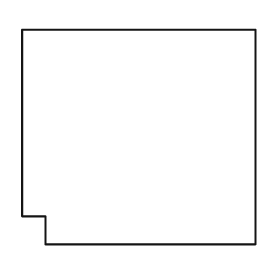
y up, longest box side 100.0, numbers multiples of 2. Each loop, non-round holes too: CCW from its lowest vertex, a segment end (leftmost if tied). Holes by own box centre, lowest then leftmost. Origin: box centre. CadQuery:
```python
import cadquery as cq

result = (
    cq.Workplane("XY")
    .moveTo(-40.0, -46.0)
    .lineTo(50.0, -46.0)
    .lineTo(50.0, 46.0)
    .lineTo(-50.0, 46.0)
    .lineTo(-50.0, -34.0)
    .lineTo(-40.0, -34.0)
    .close()
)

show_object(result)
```